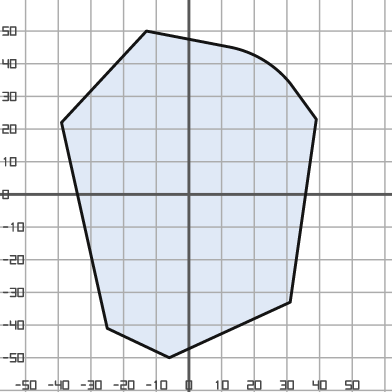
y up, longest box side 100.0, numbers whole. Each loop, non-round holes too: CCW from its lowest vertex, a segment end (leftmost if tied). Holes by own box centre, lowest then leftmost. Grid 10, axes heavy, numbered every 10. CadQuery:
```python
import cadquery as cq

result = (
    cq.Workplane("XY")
    .moveTo(-6.0, -50.0)
    .lineTo(31.0, -33.0)
    .lineTo(39.0, 23.0)
    .lineTo(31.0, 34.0)
    .threePointArc((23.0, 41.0), (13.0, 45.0))
    .lineTo(-13.0, 50.0)
    .lineTo(-39.0, 22.0)
    .lineTo(-25.0, -41.0)
    .close()
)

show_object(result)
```